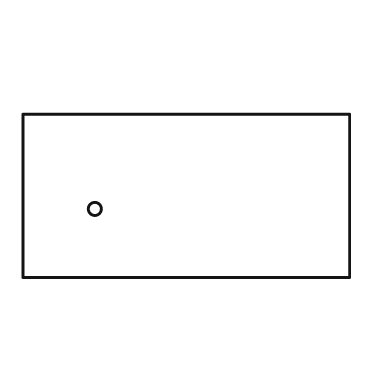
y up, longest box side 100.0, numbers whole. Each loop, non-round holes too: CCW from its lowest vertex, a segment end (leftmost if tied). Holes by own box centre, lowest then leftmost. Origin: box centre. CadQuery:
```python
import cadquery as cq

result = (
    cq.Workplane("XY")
    .moveTo(-50.0, -25.0)
    .lineTo(50.0, -25.0)
    .lineTo(50.0, 25.0)
    .lineTo(-50.0, 25.0)
    .close()
    .moveTo(-28.0, -4.0)
    .circle(2.0)
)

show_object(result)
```